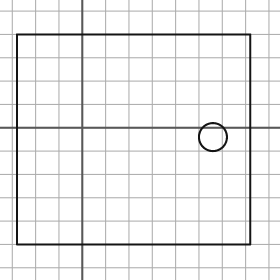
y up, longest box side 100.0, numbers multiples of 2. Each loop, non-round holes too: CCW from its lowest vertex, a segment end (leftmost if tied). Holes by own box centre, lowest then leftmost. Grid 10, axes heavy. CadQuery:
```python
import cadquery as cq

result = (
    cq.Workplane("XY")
    .moveTo(-28.0, -50.0)
    .lineTo(72.0, -50.0)
    .lineTo(72.0, 40.0)
    .lineTo(-28.0, 40.0)
    .close()
    .moveTo(56.0, -4.0)
    .circle(6.0)
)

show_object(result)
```